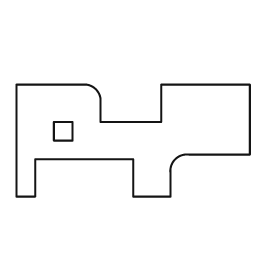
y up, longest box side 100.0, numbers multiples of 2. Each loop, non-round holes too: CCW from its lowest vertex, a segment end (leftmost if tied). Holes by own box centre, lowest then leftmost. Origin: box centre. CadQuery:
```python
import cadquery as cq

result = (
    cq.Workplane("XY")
    .moveTo(-50.0, -24.0)
    .lineTo(-42.0, -24.0)
    .lineTo(-42.0, -8.0)
    .lineTo(0.0, -8.0)
    .lineTo(0.0, -24.0)
    .lineTo(16.0, -24.0)
    .lineTo(16.0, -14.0)
    .threePointArc((18.0, -8.0), (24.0, -6.0))
    .lineTo(50.0, -6.0)
    .lineTo(50.0, 24.0)
    .lineTo(12.0, 24.0)
    .lineTo(12.0, 8.0)
    .lineTo(-14.0, 8.0)
    .lineTo(-14.0, 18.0)
    .threePointArc((-16.0, 22.0), (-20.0, 24.0))
    .lineTo(-50.0, 24.0)
    .close()
    .moveTo(-34.0, 0.0)
    .lineTo(-26.0, 0.0)
    .lineTo(-26.0, 8.0)
    .lineTo(-34.0, 8.0)
    .close()
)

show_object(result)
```